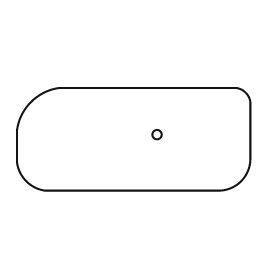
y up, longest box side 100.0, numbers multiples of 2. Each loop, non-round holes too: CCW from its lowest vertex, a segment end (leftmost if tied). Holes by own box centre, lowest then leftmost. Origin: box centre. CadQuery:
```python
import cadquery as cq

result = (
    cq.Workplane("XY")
    .moveTo(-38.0, -22.0)
    .lineTo(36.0, -22.0)
    .threePointArc((46.0, -18.0), (50.0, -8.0))
    .lineTo(50.0, 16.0)
    .threePointArc((48.0, 20.0), (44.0, 22.0))
    .lineTo(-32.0, 22.0)
    .threePointArc((-44.0, 16.0), (-50.0, 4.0))
    .lineTo(-50.0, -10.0)
    .threePointArc((-46.0, -18.0), (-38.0, -22.0))
    .close()
    .moveTo(10.0, 2.0)
    .circle(2.0)
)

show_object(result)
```